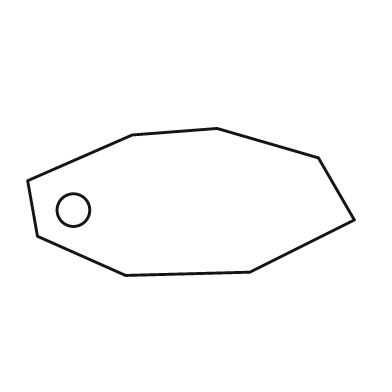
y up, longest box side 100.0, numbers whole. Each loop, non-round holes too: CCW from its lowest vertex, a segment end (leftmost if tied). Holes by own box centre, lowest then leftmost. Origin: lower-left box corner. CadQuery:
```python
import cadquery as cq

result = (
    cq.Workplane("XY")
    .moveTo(30.0, 0.0)
    .lineTo(68.0, 1.0)
    .lineTo(100.0, 17.0)
    .lineTo(89.0, 36.0)
    .lineTo(58.0, 45.0)
    .lineTo(32.0, 43.0)
    .lineTo(0.0, 29.0)
    .lineTo(3.0, 12.0)
    .close()
    .moveTo(14.0, 20.0)
    .circle(5.0)
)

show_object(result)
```